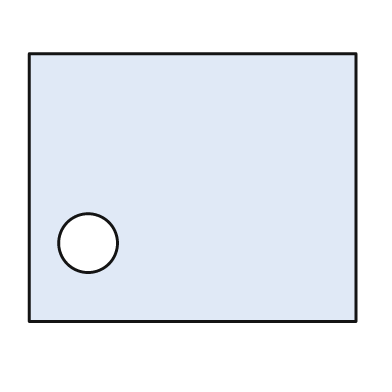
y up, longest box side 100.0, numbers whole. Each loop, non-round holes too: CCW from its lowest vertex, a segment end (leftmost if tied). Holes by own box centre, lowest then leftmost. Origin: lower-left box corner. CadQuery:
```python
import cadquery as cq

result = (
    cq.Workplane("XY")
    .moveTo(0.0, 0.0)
    .lineTo(100.0, 0.0)
    .lineTo(100.0, 82.0)
    .lineTo(0.0, 82.0)
    .close()
    .moveTo(18.0, 24.0)
    .circle(9.0)
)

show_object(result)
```